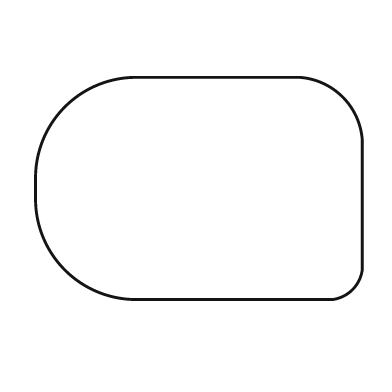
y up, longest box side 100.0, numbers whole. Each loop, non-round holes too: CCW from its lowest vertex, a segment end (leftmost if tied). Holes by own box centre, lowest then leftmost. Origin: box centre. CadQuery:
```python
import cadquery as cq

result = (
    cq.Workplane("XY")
    .moveTo(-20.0, -34.0)
    .lineTo(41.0, -34.0)
    .threePointArc((47.0, -31.0), (50.0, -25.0))
    .lineTo(50.0, 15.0)
    .threePointArc((44.0, 28.0), (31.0, 34.0))
    .lineTo(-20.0, 34.0)
    .threePointArc((-41.0, 25.0), (-50.0, 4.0))
    .lineTo(-50.0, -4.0)
    .threePointArc((-41.0, -25.0), (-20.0, -34.0))
    .close()
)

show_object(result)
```